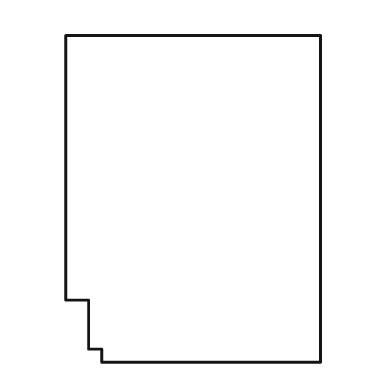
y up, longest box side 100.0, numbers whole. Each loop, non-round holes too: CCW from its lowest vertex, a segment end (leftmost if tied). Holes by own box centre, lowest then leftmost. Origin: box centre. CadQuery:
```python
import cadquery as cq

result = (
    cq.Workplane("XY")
    .moveTo(-28.0, -50.0)
    .lineTo(39.0, -50.0)
    .lineTo(39.0, 50.0)
    .lineTo(-39.0, 50.0)
    .lineTo(-39.0, -31.0)
    .lineTo(-32.0, -31.0)
    .lineTo(-32.0, -46.0)
    .lineTo(-28.0, -46.0)
    .close()
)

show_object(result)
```